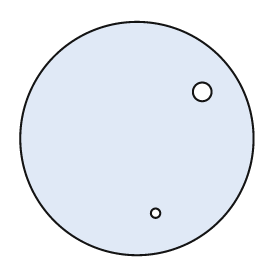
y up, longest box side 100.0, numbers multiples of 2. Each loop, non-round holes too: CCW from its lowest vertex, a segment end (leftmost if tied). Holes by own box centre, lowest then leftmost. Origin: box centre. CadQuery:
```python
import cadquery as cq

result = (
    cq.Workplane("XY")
    .moveTo(0.0, 0.0)
    .circle(50.0)
    .moveTo(8.0, -32.0)
    .circle(2.0)
    .moveTo(28.0, 20.0)
    .circle(4.0)
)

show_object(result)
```